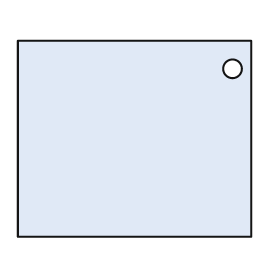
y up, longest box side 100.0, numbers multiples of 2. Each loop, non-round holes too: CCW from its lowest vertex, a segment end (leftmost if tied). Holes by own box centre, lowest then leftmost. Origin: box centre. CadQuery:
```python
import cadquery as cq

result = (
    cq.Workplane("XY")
    .moveTo(-50.0, -42.0)
    .lineTo(50.0, -42.0)
    .lineTo(50.0, 42.0)
    .lineTo(-50.0, 42.0)
    .close()
    .moveTo(42.0, 30.0)
    .circle(4.0)
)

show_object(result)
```